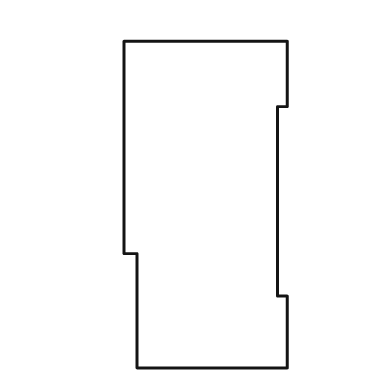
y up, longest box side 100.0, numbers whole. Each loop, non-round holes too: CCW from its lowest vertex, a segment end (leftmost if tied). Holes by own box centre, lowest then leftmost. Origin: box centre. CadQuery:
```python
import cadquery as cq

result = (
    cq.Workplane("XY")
    .moveTo(-21.0, -50.0)
    .lineTo(25.0, -50.0)
    .lineTo(25.0, -28.0)
    .lineTo(22.0, -28.0)
    .lineTo(22.0, 30.0)
    .lineTo(25.0, 30.0)
    .lineTo(25.0, 50.0)
    .lineTo(-25.0, 50.0)
    .lineTo(-25.0, -15.0)
    .lineTo(-21.0, -15.0)
    .close()
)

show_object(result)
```